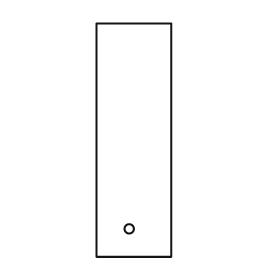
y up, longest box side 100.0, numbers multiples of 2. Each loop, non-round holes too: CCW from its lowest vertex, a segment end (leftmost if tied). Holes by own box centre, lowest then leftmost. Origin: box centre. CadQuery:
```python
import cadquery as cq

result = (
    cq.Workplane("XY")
    .moveTo(-16.0, -50.0)
    .lineTo(16.0, -50.0)
    .lineTo(16.0, 50.0)
    .lineTo(-16.0, 50.0)
    .close()
    .moveTo(-2.0, -38.0)
    .circle(2.0)
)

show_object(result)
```